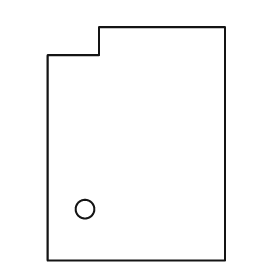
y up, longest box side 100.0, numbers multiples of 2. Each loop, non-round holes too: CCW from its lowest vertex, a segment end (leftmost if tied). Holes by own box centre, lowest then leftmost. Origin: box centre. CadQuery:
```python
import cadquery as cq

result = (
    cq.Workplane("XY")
    .moveTo(-38.0, -50.0)
    .lineTo(38.0, -50.0)
    .lineTo(38.0, 50.0)
    .lineTo(-16.0, 50.0)
    .lineTo(-16.0, 38.0)
    .lineTo(-38.0, 38.0)
    .close()
    .moveTo(-22.0, -28.0)
    .circle(4.0)
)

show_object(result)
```